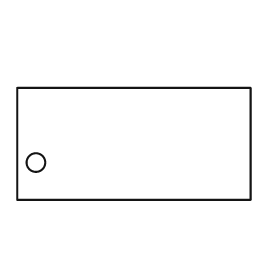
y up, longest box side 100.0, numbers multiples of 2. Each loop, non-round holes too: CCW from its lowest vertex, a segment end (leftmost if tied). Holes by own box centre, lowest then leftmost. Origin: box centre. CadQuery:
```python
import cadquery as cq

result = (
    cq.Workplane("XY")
    .moveTo(-50.0, -24.0)
    .lineTo(50.0, -24.0)
    .lineTo(50.0, 24.0)
    .lineTo(-50.0, 24.0)
    .close()
    .moveTo(-42.0, -8.0)
    .circle(4.0)
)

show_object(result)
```